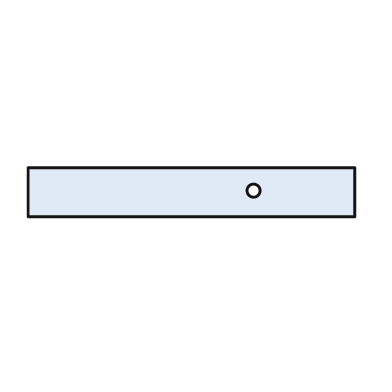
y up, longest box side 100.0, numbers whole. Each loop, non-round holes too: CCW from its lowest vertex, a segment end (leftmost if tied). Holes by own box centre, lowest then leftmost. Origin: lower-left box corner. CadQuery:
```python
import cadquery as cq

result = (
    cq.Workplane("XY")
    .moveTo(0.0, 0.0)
    .lineTo(100.0, 0.0)
    .lineTo(100.0, 15.0)
    .lineTo(0.0, 15.0)
    .close()
    .moveTo(69.0, 8.0)
    .circle(2.0)
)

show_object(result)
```